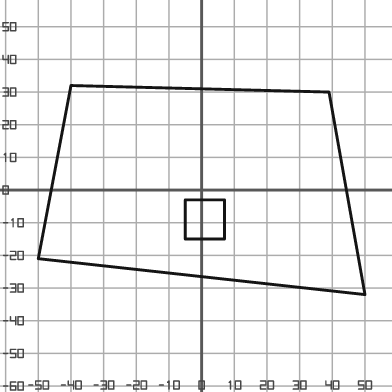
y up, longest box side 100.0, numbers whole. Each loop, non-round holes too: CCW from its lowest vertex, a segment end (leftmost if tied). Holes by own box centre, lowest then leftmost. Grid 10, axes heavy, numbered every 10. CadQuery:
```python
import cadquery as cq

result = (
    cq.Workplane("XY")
    .moveTo(50.0, -32.0)
    .lineTo(39.0, 30.0)
    .lineTo(-40.0, 32.0)
    .lineTo(-50.0, -21.0)
    .close()
    .moveTo(-5.0, -15.0)
    .lineTo(7.0, -15.0)
    .lineTo(7.0, -3.0)
    .lineTo(-5.0, -3.0)
    .close()
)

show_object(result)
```